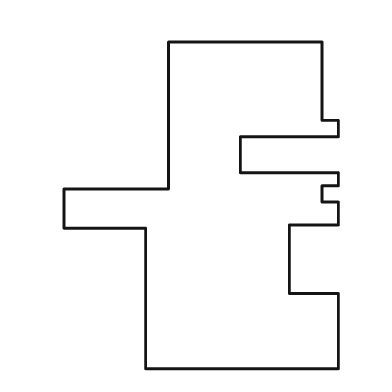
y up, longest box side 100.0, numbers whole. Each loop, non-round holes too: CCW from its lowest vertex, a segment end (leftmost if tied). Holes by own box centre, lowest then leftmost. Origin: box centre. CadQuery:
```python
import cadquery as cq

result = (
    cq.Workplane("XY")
    .moveTo(-17.0, -50.0)
    .lineTo(42.0, -50.0)
    .lineTo(42.0, -27.0)
    .lineTo(27.0, -27.0)
    .lineTo(27.0, -6.0)
    .lineTo(42.0, -6.0)
    .lineTo(42.0, 1.0)
    .lineTo(37.0, 1.0)
    .lineTo(37.0, 6.0)
    .lineTo(42.0, 6.0)
    .lineTo(42.0, 10.0)
    .lineTo(12.0, 10.0)
    .lineTo(12.0, 21.0)
    .lineTo(42.0, 21.0)
    .lineTo(42.0, 26.0)
    .lineTo(37.0, 26.0)
    .lineTo(37.0, 50.0)
    .lineTo(-10.0, 50.0)
    .lineTo(-10.0, 5.0)
    .lineTo(-42.0, 5.0)
    .lineTo(-42.0, -7.0)
    .lineTo(-17.0, -7.0)
    .close()
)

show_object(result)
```